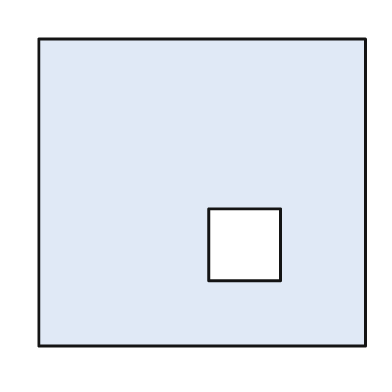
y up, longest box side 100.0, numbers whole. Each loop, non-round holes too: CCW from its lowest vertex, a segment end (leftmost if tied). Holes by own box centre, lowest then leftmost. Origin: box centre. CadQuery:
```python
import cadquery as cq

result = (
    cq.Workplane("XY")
    .moveTo(-50.0, -47.0)
    .lineTo(50.0, -47.0)
    .lineTo(50.0, 47.0)
    .lineTo(-50.0, 47.0)
    .close()
    .moveTo(2.0, -27.0)
    .lineTo(24.0, -27.0)
    .lineTo(24.0, -5.0)
    .lineTo(2.0, -5.0)
    .close()
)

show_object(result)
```